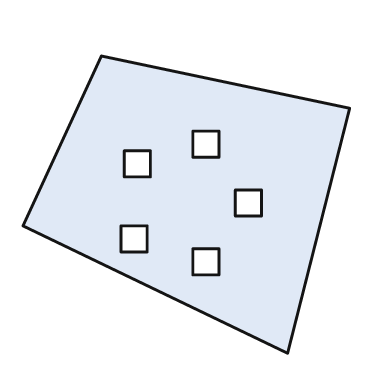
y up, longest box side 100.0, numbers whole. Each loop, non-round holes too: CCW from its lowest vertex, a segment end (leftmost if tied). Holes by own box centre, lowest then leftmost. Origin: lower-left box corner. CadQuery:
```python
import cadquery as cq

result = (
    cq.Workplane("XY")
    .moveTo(81.0, 0.0)
    .lineTo(100.0, 75.0)
    .lineTo(24.0, 91.0)
    .lineTo(0.0, 39.0)
    .close()
    .moveTo(52.0, 24.0)
    .lineTo(60.0, 24.0)
    .lineTo(60.0, 32.0)
    .lineTo(52.0, 32.0)
    .close()
    .moveTo(30.0, 31.0)
    .lineTo(38.0, 31.0)
    .lineTo(38.0, 39.0)
    .lineTo(30.0, 39.0)
    .close()
    .moveTo(65.0, 42.0)
    .lineTo(73.0, 42.0)
    .lineTo(73.0, 50.0)
    .lineTo(65.0, 50.0)
    .close()
    .moveTo(31.0, 54.0)
    .lineTo(39.0, 54.0)
    .lineTo(39.0, 62.0)
    .lineTo(31.0, 62.0)
    .close()
    .moveTo(52.0, 60.0)
    .lineTo(60.0, 60.0)
    .lineTo(60.0, 68.0)
    .lineTo(52.0, 68.0)
    .close()
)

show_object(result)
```